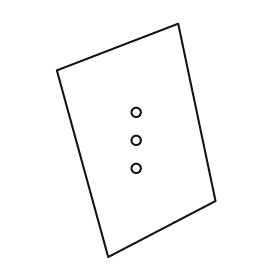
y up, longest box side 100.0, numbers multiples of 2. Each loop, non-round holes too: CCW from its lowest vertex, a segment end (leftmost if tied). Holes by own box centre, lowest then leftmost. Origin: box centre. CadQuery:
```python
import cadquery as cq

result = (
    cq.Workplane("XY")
    .moveTo(-12.0, -50.0)
    .lineTo(34.0, -26.0)
    .lineTo(18.0, 50.0)
    .lineTo(-34.0, 30.0)
    .close()
    .moveTo(0.0, -12.0)
    .circle(2.0)
    .moveTo(0.0, 0.0)
    .circle(2.0)
    .moveTo(0.0, 12.0)
    .circle(2.0)
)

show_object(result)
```